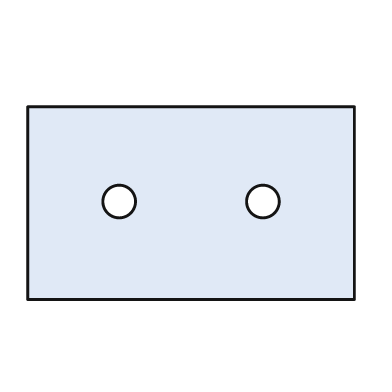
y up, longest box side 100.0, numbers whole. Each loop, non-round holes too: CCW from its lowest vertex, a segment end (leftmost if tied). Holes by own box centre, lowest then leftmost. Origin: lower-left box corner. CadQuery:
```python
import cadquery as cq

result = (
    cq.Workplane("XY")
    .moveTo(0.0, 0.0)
    .lineTo(100.0, 0.0)
    .lineTo(100.0, 59.0)
    .lineTo(0.0, 59.0)
    .close()
    .moveTo(28.0, 30.0)
    .circle(5.0)
    .moveTo(72.0, 30.0)
    .circle(5.0)
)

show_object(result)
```